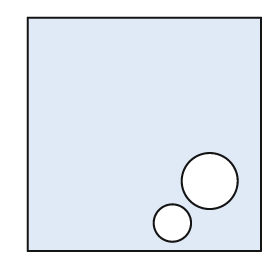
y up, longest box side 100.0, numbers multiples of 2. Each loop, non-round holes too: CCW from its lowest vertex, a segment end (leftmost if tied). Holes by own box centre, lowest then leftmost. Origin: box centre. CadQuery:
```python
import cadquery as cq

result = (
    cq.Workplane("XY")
    .moveTo(-50.0, -50.0)
    .lineTo(50.0, -50.0)
    .lineTo(50.0, 50.0)
    .lineTo(-50.0, 50.0)
    .close()
    .moveTo(12.0, -38.0)
    .circle(8.0)
    .moveTo(28.0, -20.0)
    .circle(12.0)
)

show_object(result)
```